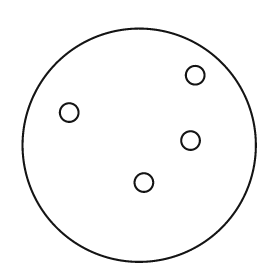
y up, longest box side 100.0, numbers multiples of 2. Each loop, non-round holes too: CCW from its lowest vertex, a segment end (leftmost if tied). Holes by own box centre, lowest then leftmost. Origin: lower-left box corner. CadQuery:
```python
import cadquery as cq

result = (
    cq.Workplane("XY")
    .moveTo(50.0, 50.0)
    .circle(50.0)
    .moveTo(52.0, 34.0)
    .circle(4.0)
    .moveTo(72.0, 52.0)
    .circle(4.0)
    .moveTo(20.0, 64.0)
    .circle(4.0)
    .moveTo(74.0, 80.0)
    .circle(4.0)
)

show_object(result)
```